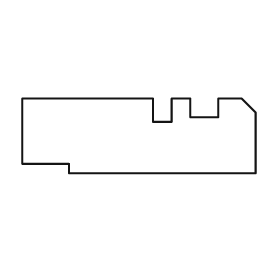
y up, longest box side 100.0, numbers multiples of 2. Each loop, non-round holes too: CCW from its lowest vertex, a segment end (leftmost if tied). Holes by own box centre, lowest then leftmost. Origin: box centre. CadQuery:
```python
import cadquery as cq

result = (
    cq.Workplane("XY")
    .moveTo(-30.0, -16.0)
    .lineTo(50.0, -16.0)
    .lineTo(50.0, 10.0)
    .lineTo(44.0, 16.0)
    .lineTo(34.0, 16.0)
    .lineTo(34.0, 8.0)
    .lineTo(22.0, 8.0)
    .lineTo(22.0, 16.0)
    .lineTo(14.0, 16.0)
    .lineTo(14.0, 6.0)
    .lineTo(6.0, 6.0)
    .lineTo(6.0, 16.0)
    .lineTo(-50.0, 16.0)
    .lineTo(-50.0, -12.0)
    .lineTo(-30.0, -12.0)
    .close()
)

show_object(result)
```